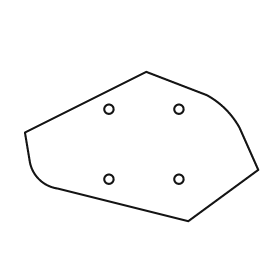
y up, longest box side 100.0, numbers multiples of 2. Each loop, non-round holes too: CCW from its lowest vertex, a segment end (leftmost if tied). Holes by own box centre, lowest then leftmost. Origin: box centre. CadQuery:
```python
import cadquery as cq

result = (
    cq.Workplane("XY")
    .moveTo(20.0, -32.0)
    .lineTo(50.0, -10.0)
    .lineTo(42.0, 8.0)
    .threePointArc((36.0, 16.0), (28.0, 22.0))
    .lineTo(2.0, 32.0)
    .lineTo(-50.0, 6.0)
    .lineTo(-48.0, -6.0)
    .threePointArc((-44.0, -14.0), (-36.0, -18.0))
    .close()
    .moveTo(-14.0, -14.0)
    .circle(2.0)
    .moveTo(16.0, -14.0)
    .circle(2.0)
    .moveTo(-14.0, 16.0)
    .circle(2.0)
    .moveTo(16.0, 16.0)
    .circle(2.0)
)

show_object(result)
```